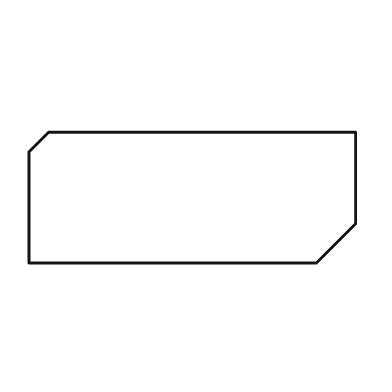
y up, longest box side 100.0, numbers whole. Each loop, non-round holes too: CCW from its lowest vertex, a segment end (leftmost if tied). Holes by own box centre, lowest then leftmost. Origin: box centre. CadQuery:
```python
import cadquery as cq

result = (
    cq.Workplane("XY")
    .moveTo(-50.0, -20.0)
    .lineTo(38.0, -20.0)
    .lineTo(50.0, -8.0)
    .lineTo(50.0, 20.0)
    .lineTo(-44.0, 20.0)
    .lineTo(-50.0, 14.0)
    .close()
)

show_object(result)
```